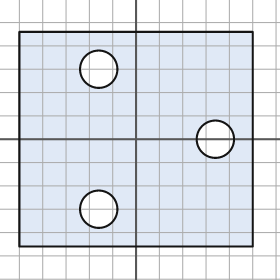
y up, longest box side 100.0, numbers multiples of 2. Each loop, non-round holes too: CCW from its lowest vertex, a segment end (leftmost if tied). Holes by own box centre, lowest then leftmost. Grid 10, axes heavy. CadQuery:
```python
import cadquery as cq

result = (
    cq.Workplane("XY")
    .moveTo(-50.0, -46.0)
    .lineTo(50.0, -46.0)
    .lineTo(50.0, 46.0)
    .lineTo(-50.0, 46.0)
    .close()
    .moveTo(-16.0, -30.0)
    .circle(8.0)
    .moveTo(34.0, 0.0)
    .circle(8.0)
    .moveTo(-16.0, 30.0)
    .circle(8.0)
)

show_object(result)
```